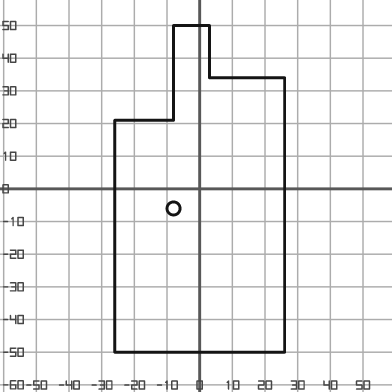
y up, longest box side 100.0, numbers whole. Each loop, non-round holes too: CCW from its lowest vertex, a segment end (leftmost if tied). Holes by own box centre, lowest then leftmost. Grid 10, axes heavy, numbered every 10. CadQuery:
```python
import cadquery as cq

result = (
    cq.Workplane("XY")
    .moveTo(-26.0, -50.0)
    .lineTo(26.0, -50.0)
    .lineTo(26.0, 34.0)
    .lineTo(3.0, 34.0)
    .lineTo(3.0, 50.0)
    .lineTo(-8.0, 50.0)
    .lineTo(-8.0, 21.0)
    .lineTo(-26.0, 21.0)
    .close()
    .moveTo(-8.0, -6.0)
    .circle(2.0)
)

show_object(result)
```